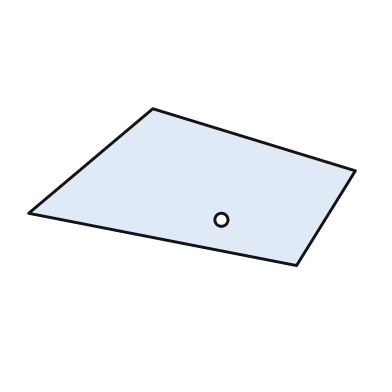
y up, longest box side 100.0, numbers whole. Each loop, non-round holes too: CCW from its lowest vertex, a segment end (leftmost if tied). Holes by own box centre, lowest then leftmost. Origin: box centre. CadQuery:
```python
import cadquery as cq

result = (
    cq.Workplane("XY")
    .moveTo(32.0, -24.0)
    .lineTo(50.0, 5.0)
    .lineTo(-12.0, 24.0)
    .lineTo(-50.0, -8.0)
    .close()
    .moveTo(9.0, -10.0)
    .circle(2.0)
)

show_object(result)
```